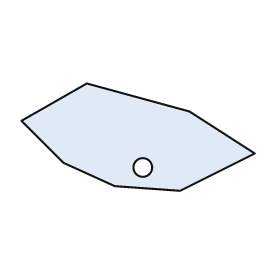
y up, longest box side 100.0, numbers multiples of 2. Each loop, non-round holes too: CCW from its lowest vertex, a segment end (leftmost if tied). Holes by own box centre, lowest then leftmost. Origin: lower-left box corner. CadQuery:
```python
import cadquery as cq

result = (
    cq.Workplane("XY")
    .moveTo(68.0, 0.0)
    .lineTo(100.0, 16.0)
    .lineTo(72.0, 34.0)
    .lineTo(28.0, 46.0)
    .lineTo(0.0, 30.0)
    .lineTo(18.0, 12.0)
    .lineTo(40.0, 2.0)
    .close()
    .moveTo(52.0, 10.0)
    .circle(4.0)
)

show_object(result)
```